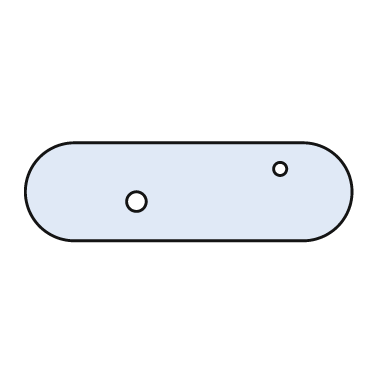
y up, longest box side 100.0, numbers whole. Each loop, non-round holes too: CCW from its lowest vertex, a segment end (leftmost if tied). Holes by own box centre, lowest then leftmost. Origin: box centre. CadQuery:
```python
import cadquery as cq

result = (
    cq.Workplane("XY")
    .moveTo(-35.0, -15.0)
    .lineTo(35.0, -15.0)
    .threePointArc((50.0, 0.0), (35.0, 15.0))
    .lineTo(-35.0, 15.0)
    .threePointArc((-50.0, 0.0), (-35.0, -15.0))
    .close()
    .moveTo(-16.0, -3.0)
    .circle(3.0)
    .moveTo(28.0, 7.0)
    .circle(2.0)
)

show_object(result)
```